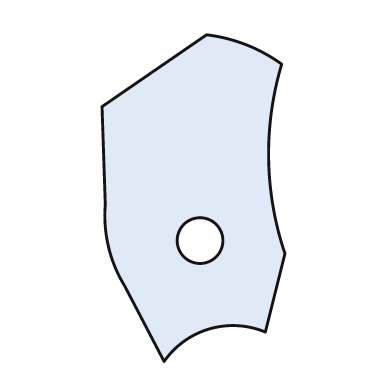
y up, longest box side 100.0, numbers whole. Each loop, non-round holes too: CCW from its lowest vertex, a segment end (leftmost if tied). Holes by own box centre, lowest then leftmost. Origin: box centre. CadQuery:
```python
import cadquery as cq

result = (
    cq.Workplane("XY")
    .moveTo(-9.0, -50.0)
    .threePointArc((5.0, -40.0), (22.0, -41.0))
    .lineTo(28.0, -17.0)
    .threePointArc((23.0, 12.0), (27.0, 41.0))
    .threePointArc((16.0, 47.0), (4.0, 50.0))
    .lineTo(-28.0, 28.0)
    .lineTo(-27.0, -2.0)
    .threePointArc((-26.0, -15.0), (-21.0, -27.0))
    .close()
    .moveTo(2.0, -13.0)
    .circle(7.0)
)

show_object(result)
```